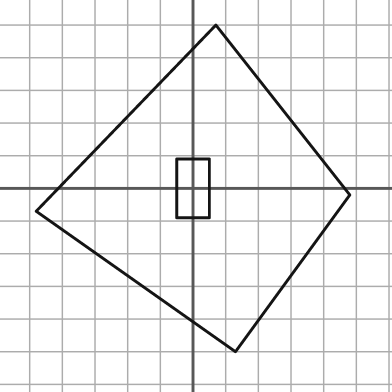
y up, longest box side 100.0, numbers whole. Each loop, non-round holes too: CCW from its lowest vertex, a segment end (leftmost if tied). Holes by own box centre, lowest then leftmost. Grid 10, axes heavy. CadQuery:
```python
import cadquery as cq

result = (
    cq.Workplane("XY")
    .moveTo(13.0, -50.0)
    .lineTo(48.0, -2.0)
    .lineTo(7.0, 50.0)
    .lineTo(-48.0, -7.0)
    .close()
    .moveTo(-5.0, -9.0)
    .lineTo(5.0, -9.0)
    .lineTo(5.0, 9.0)
    .lineTo(-5.0, 9.0)
    .close()
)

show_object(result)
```